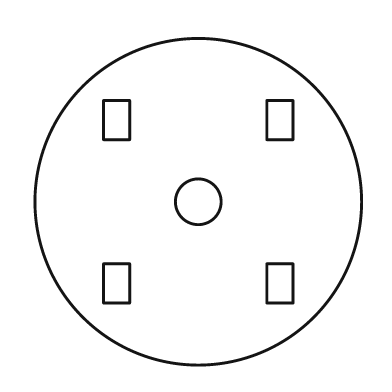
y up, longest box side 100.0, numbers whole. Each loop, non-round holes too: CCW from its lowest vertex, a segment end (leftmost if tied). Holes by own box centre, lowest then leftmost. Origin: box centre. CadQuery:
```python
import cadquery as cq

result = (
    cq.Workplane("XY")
    .moveTo(0.0, 0.0)
    .circle(50.0)
    .moveTo(-29.0, -31.0)
    .lineTo(-21.0, -31.0)
    .lineTo(-21.0, -19.0)
    .lineTo(-29.0, -19.0)
    .close()
    .moveTo(21.0, -31.0)
    .lineTo(29.0, -31.0)
    .lineTo(29.0, -19.0)
    .lineTo(21.0, -19.0)
    .close()
    .moveTo(0.0, 0.0)
    .circle(7.0)
    .moveTo(-29.0, 19.0)
    .lineTo(-21.0, 19.0)
    .lineTo(-21.0, 31.0)
    .lineTo(-29.0, 31.0)
    .close()
    .moveTo(21.0, 19.0)
    .lineTo(29.0, 19.0)
    .lineTo(29.0, 31.0)
    .lineTo(21.0, 31.0)
    .close()
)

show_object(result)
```